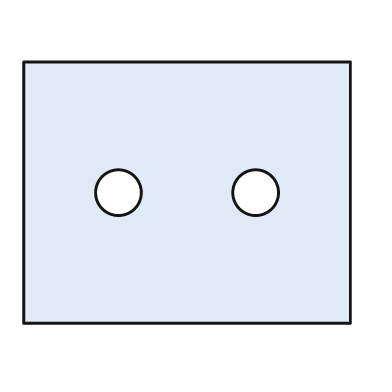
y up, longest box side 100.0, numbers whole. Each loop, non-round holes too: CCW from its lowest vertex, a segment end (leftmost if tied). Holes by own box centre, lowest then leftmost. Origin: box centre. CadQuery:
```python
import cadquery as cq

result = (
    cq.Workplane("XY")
    .moveTo(-50.0, -40.0)
    .lineTo(50.0, -40.0)
    .lineTo(50.0, 40.0)
    .lineTo(-50.0, 40.0)
    .close()
    .moveTo(-21.0, 0.0)
    .circle(7.0)
    .moveTo(21.0, 0.0)
    .circle(7.0)
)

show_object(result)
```